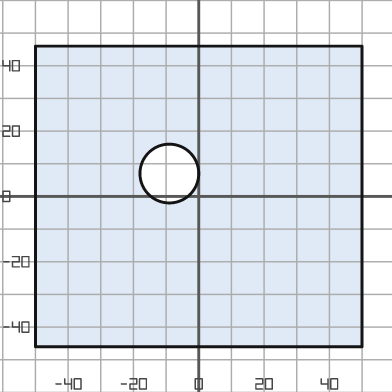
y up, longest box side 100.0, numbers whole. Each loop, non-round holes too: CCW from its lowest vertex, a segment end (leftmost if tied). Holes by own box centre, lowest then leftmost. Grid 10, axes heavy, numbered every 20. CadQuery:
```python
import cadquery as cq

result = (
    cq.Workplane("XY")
    .moveTo(-50.0, -46.0)
    .lineTo(50.0, -46.0)
    .lineTo(50.0, 46.0)
    .lineTo(-50.0, 46.0)
    .close()
    .moveTo(-9.0, 7.0)
    .circle(9.0)
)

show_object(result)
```